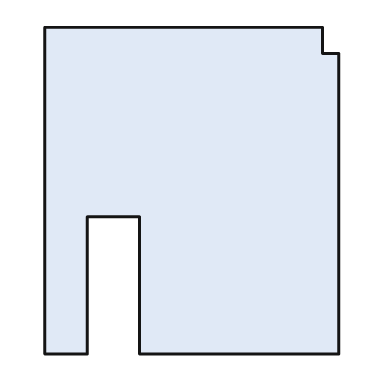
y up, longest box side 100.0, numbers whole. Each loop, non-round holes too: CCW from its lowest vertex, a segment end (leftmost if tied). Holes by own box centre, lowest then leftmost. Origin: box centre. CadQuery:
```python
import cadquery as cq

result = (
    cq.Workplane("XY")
    .moveTo(-45.0, -50.0)
    .lineTo(-32.0, -50.0)
    .lineTo(-32.0, -8.0)
    .lineTo(-16.0, -8.0)
    .lineTo(-16.0, -50.0)
    .lineTo(45.0, -50.0)
    .lineTo(45.0, 42.0)
    .lineTo(40.0, 42.0)
    .lineTo(40.0, 50.0)
    .lineTo(-45.0, 50.0)
    .close()
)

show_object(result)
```